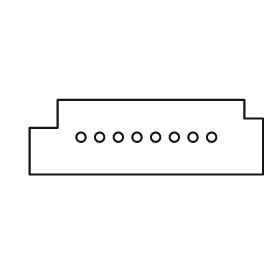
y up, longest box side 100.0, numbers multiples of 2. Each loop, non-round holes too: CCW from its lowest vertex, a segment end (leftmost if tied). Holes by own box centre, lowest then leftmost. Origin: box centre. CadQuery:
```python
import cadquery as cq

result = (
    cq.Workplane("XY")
    .moveTo(-50.0, -16.0)
    .lineTo(50.0, -16.0)
    .lineTo(50.0, 8.0)
    .lineTo(42.0, 8.0)
    .lineTo(42.0, 16.0)
    .lineTo(-38.0, 16.0)
    .lineTo(-38.0, 4.0)
    .lineTo(-50.0, 4.0)
    .close()
    .moveTo(-28.0, 0.0)
    .circle(2.0)
    .moveTo(-20.0, 0.0)
    .circle(2.0)
    .moveTo(-12.0, 0.0)
    .circle(2.0)
    .moveTo(-4.0, 0.0)
    .circle(2.0)
    .moveTo(4.0, 0.0)
    .circle(2.0)
    .moveTo(12.0, 0.0)
    .circle(2.0)
    .moveTo(20.0, 0.0)
    .circle(2.0)
    .moveTo(28.0, 0.0)
    .circle(2.0)
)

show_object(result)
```